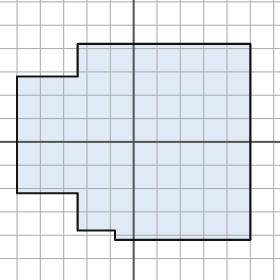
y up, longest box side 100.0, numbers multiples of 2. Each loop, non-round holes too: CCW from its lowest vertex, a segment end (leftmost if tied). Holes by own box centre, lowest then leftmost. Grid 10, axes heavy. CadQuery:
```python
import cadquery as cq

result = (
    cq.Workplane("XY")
    .moveTo(-8.0, -42.0)
    .lineTo(50.0, -42.0)
    .lineTo(50.0, 42.0)
    .lineTo(-24.0, 42.0)
    .lineTo(-24.0, 28.0)
    .lineTo(-50.0, 28.0)
    .lineTo(-50.0, -22.0)
    .lineTo(-24.0, -22.0)
    .lineTo(-24.0, -38.0)
    .lineTo(-8.0, -38.0)
    .close()
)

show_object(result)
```